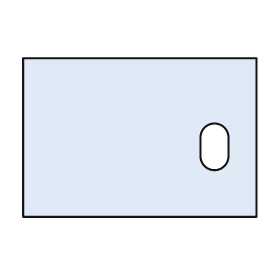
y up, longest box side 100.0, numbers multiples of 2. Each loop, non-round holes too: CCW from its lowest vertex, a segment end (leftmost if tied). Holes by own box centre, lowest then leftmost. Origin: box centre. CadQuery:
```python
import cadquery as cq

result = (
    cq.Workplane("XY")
    .moveTo(-50.0, -34.0)
    .lineTo(50.0, -34.0)
    .lineTo(50.0, 34.0)
    .lineTo(-50.0, 34.0)
    .close()
    .moveTo(26.0, -8.0)
    .threePointArc((32.0, -14.0), (38.0, -8.0))
    .lineTo(38.0, 0.0)
    .threePointArc((32.0, 6.0), (26.0, 0.0))
    .close()
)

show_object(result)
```